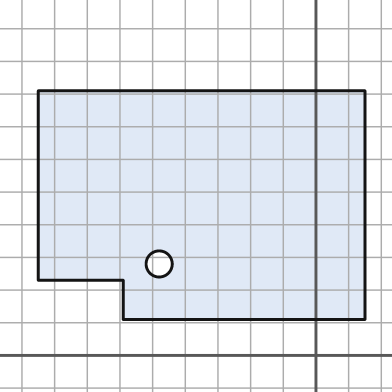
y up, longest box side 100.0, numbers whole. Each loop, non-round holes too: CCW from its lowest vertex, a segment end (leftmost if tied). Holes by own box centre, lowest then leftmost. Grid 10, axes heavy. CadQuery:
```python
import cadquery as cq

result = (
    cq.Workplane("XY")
    .moveTo(-59.0, 11.0)
    .lineTo(15.0, 11.0)
    .lineTo(15.0, 81.0)
    .lineTo(-85.0, 81.0)
    .lineTo(-85.0, 23.0)
    .lineTo(-59.0, 23.0)
    .close()
    .moveTo(-48.0, 28.0)
    .circle(4.0)
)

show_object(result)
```